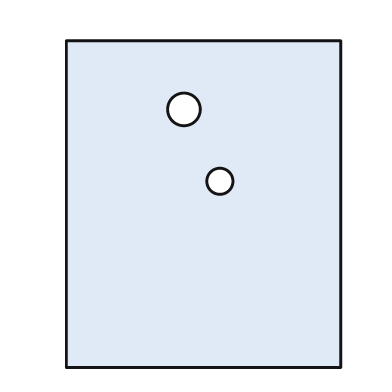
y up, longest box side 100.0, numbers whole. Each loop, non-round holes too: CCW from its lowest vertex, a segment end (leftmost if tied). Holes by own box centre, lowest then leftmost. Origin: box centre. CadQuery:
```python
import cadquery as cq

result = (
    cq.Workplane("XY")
    .moveTo(-42.0, -50.0)
    .lineTo(42.0, -50.0)
    .lineTo(42.0, 50.0)
    .lineTo(-42.0, 50.0)
    .close()
    .moveTo(5.0, 7.0)
    .circle(4.0)
    .moveTo(-6.0, 29.0)
    .circle(5.0)
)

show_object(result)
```